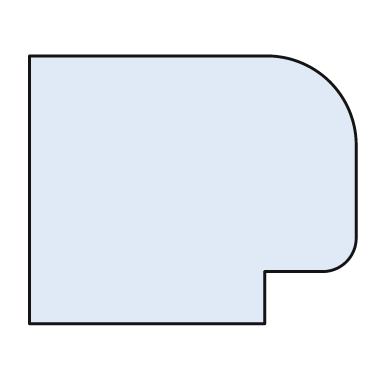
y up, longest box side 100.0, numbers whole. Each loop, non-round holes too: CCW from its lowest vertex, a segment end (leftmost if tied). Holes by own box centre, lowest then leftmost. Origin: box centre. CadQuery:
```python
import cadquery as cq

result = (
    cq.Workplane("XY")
    .moveTo(-50.0, -41.0)
    .lineTo(22.0, -41.0)
    .lineTo(22.0, -25.0)
    .lineTo(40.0, -25.0)
    .threePointArc((47.0, -22.0), (50.0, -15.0))
    .lineTo(50.0, 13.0)
    .threePointArc((42.0, 33.0), (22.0, 41.0))
    .lineTo(-50.0, 41.0)
    .close()
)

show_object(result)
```